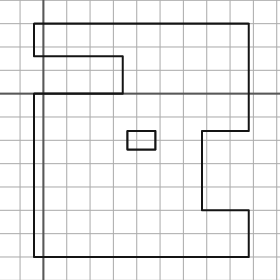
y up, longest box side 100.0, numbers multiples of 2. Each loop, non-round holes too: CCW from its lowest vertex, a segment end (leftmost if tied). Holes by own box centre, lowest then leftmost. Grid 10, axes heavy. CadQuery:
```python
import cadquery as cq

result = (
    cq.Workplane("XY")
    .moveTo(-4.0, -70.0)
    .lineTo(88.0, -70.0)
    .lineTo(88.0, -50.0)
    .lineTo(68.0, -50.0)
    .lineTo(68.0, -16.0)
    .lineTo(88.0, -16.0)
    .lineTo(88.0, 30.0)
    .lineTo(-4.0, 30.0)
    .lineTo(-4.0, 16.0)
    .lineTo(34.0, 16.0)
    .lineTo(34.0, 0.0)
    .lineTo(-4.0, 0.0)
    .close()
    .moveTo(36.0, -24.0)
    .lineTo(48.0, -24.0)
    .lineTo(48.0, -16.0)
    .lineTo(36.0, -16.0)
    .close()
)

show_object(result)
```